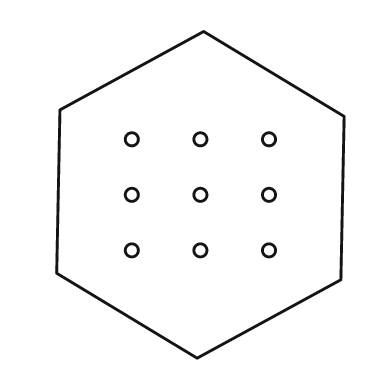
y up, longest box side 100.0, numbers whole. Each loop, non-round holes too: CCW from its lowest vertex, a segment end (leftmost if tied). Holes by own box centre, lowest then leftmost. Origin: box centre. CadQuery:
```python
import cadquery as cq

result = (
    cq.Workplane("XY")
    .moveTo(-1.0, -50.0)
    .lineTo(43.0, -26.0)
    .lineTo(44.0, 24.0)
    .lineTo(1.0, 50.0)
    .lineTo(-43.0, 26.0)
    .lineTo(-44.0, -24.0)
    .close()
    .moveTo(-21.0, -17.0)
    .circle(2.0)
    .moveTo(0.0, -17.0)
    .circle(2.0)
    .moveTo(21.0, -17.0)
    .circle(2.0)
    .moveTo(-21.0, 0.0)
    .circle(2.0)
    .moveTo(0.0, 0.0)
    .circle(2.0)
    .moveTo(21.0, 0.0)
    .circle(2.0)
    .moveTo(-21.0, 17.0)
    .circle(2.0)
    .moveTo(0.0, 17.0)
    .circle(2.0)
    .moveTo(21.0, 17.0)
    .circle(2.0)
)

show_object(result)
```